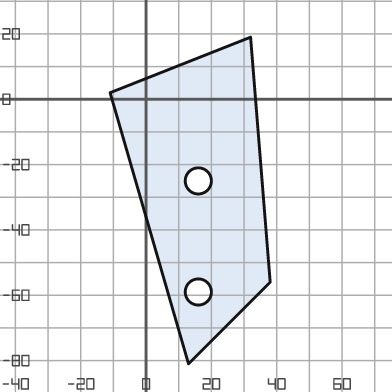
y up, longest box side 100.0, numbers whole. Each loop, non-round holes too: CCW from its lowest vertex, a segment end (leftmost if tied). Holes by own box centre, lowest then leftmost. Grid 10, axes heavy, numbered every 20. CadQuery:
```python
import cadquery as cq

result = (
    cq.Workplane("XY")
    .moveTo(13.0, -81.0)
    .lineTo(38.0, -56.0)
    .lineTo(32.0, 19.0)
    .lineTo(-11.0, 2.0)
    .close()
    .moveTo(16.0, -59.0)
    .circle(4.0)
    .moveTo(16.0, -25.0)
    .circle(4.0)
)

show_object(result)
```